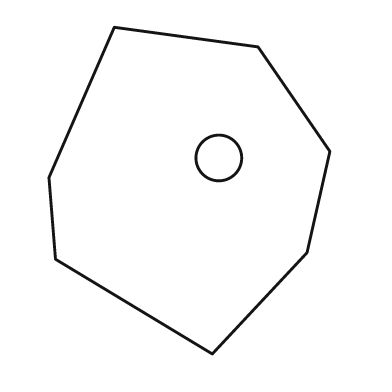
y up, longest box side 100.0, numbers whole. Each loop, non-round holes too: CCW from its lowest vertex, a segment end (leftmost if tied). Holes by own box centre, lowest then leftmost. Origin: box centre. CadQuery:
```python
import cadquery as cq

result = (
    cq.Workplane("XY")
    .moveTo(7.0, -50.0)
    .lineTo(36.0, -19.0)
    .lineTo(43.0, 12.0)
    .lineTo(21.0, 44.0)
    .lineTo(-23.0, 50.0)
    .lineTo(-43.0, 4.0)
    .lineTo(-41.0, -21.0)
    .close()
    .moveTo(9.0, 10.0)
    .circle(7.0)
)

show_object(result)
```